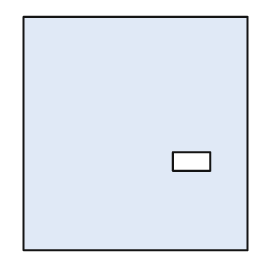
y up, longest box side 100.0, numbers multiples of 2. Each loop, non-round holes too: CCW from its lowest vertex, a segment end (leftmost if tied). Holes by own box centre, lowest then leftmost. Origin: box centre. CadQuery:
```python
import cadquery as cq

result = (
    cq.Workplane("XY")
    .moveTo(-48.0, -50.0)
    .lineTo(48.0, -50.0)
    .lineTo(48.0, 50.0)
    .lineTo(-48.0, 50.0)
    .close()
    .moveTo(16.0, -16.0)
    .lineTo(32.0, -16.0)
    .lineTo(32.0, -8.0)
    .lineTo(16.0, -8.0)
    .close()
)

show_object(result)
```